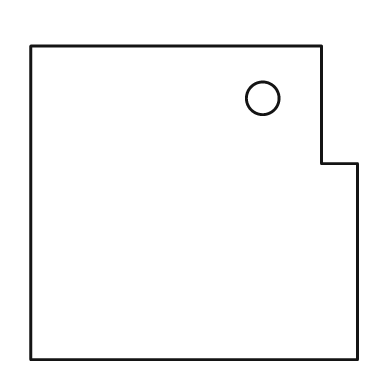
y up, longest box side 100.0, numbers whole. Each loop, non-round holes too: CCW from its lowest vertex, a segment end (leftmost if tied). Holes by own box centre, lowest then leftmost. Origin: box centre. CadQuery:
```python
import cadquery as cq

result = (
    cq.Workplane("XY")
    .moveTo(-50.0, -48.0)
    .lineTo(50.0, -48.0)
    .lineTo(50.0, 12.0)
    .lineTo(39.0, 12.0)
    .lineTo(39.0, 48.0)
    .lineTo(-50.0, 48.0)
    .close()
    .moveTo(21.0, 32.0)
    .circle(5.0)
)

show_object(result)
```